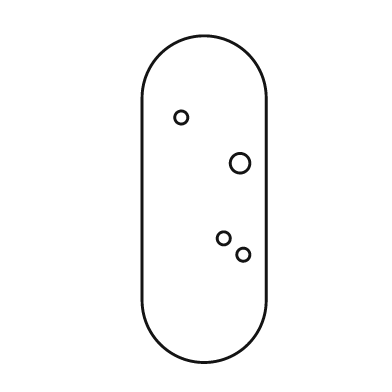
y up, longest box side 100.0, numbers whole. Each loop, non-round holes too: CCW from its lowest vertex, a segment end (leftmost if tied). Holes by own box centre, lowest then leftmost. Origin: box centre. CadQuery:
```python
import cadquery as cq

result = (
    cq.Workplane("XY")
    .moveTo(-19.0, -31.0)
    .threePointArc((0.0, -50.0), (19.0, -31.0))
    .lineTo(19.0, 31.0)
    .threePointArc((0.0, 50.0), (-19.0, 31.0))
    .close()
    .moveTo(12.0, -17.0)
    .circle(2.0)
    .moveTo(6.0, -12.0)
    .circle(2.0)
    .moveTo(11.0, 11.0)
    .circle(3.0)
    .moveTo(-7.0, 25.0)
    .circle(2.0)
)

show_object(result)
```